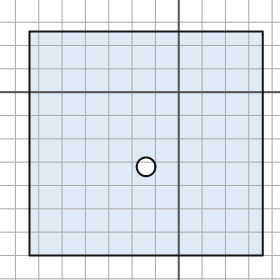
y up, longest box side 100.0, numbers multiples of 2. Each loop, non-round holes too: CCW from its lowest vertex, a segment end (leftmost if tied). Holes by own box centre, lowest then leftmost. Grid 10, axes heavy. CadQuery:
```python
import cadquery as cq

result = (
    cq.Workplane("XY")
    .moveTo(-64.0, -70.0)
    .lineTo(36.0, -70.0)
    .lineTo(36.0, 26.0)
    .lineTo(-64.0, 26.0)
    .close()
    .moveTo(-14.0, -32.0)
    .circle(4.0)
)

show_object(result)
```